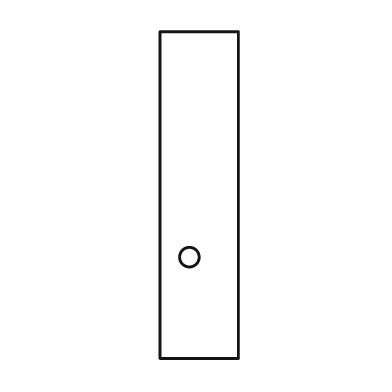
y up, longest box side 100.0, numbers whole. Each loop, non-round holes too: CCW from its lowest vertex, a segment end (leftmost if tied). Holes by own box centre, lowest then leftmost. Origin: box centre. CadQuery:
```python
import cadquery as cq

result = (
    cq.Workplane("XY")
    .moveTo(-12.0, -50.0)
    .lineTo(12.0, -50.0)
    .lineTo(12.0, 50.0)
    .lineTo(-12.0, 50.0)
    .close()
    .moveTo(-3.0, -19.0)
    .circle(3.0)
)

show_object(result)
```